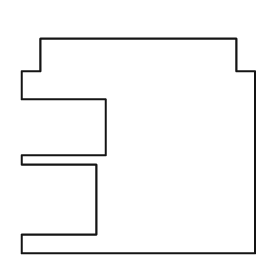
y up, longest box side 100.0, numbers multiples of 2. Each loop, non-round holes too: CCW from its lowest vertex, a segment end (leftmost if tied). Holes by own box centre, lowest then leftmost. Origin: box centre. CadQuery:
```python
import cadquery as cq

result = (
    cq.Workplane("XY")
    .moveTo(-50.0, -46.0)
    .lineTo(50.0, -46.0)
    .lineTo(50.0, 32.0)
    .lineTo(42.0, 32.0)
    .lineTo(42.0, 46.0)
    .lineTo(-42.0, 46.0)
    .lineTo(-42.0, 32.0)
    .lineTo(-50.0, 32.0)
    .lineTo(-50.0, 20.0)
    .lineTo(-14.0, 20.0)
    .lineTo(-14.0, -4.0)
    .lineTo(-50.0, -4.0)
    .lineTo(-50.0, -8.0)
    .lineTo(-18.0, -8.0)
    .lineTo(-18.0, -38.0)
    .lineTo(-50.0, -38.0)
    .close()
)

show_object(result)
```